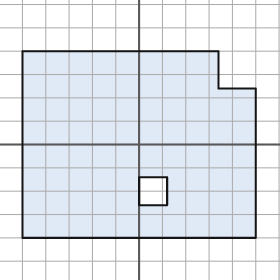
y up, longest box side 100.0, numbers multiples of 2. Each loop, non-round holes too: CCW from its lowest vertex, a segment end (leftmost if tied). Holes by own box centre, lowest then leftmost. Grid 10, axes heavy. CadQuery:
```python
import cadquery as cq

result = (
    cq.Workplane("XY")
    .moveTo(-50.0, -40.0)
    .lineTo(50.0, -40.0)
    .lineTo(50.0, 24.0)
    .lineTo(34.0, 24.0)
    .lineTo(34.0, 40.0)
    .lineTo(-50.0, 40.0)
    .close()
    .moveTo(0.0, -26.0)
    .lineTo(12.0, -26.0)
    .lineTo(12.0, -14.0)
    .lineTo(0.0, -14.0)
    .close()
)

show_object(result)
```